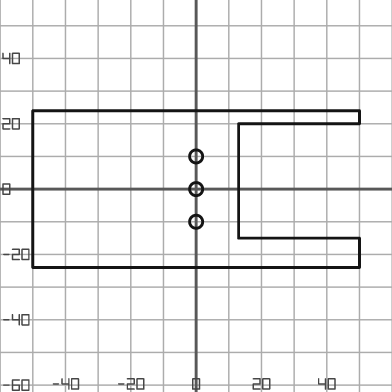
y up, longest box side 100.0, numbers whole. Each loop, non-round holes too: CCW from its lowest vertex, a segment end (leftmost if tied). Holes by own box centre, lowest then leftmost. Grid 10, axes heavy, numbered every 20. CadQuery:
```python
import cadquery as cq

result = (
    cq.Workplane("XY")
    .moveTo(-50.0, -24.0)
    .lineTo(50.0, -24.0)
    .lineTo(50.0, -15.0)
    .lineTo(13.0, -15.0)
    .lineTo(13.0, 20.0)
    .lineTo(50.0, 20.0)
    .lineTo(50.0, 24.0)
    .lineTo(-50.0, 24.0)
    .close()
    .moveTo(0.0, -10.0)
    .circle(2.0)
    .moveTo(0.0, 0.0)
    .circle(2.0)
    .moveTo(0.0, 10.0)
    .circle(2.0)
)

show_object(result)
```